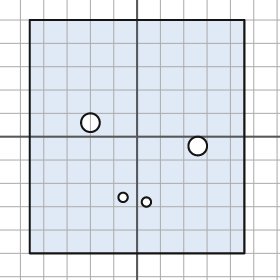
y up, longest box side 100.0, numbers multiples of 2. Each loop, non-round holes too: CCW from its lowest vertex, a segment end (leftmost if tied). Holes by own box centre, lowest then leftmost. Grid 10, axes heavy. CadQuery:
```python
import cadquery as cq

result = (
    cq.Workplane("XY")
    .moveTo(-46.0, -50.0)
    .lineTo(46.0, -50.0)
    .lineTo(46.0, 50.0)
    .lineTo(-46.0, 50.0)
    .close()
    .moveTo(4.0, -28.0)
    .circle(2.0)
    .moveTo(-6.0, -26.0)
    .circle(2.0)
    .moveTo(26.0, -4.0)
    .circle(4.0)
    .moveTo(-20.0, 6.0)
    .circle(4.0)
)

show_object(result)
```